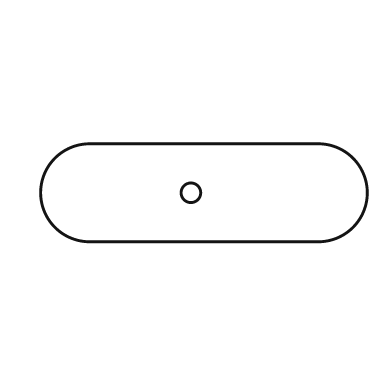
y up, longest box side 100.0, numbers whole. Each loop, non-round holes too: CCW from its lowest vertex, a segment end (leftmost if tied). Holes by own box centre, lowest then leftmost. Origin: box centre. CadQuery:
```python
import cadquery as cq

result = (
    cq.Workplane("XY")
    .moveTo(-35.0, -15.0)
    .lineTo(35.0, -15.0)
    .threePointArc((50.0, 0.0), (35.0, 15.0))
    .lineTo(-35.0, 15.0)
    .threePointArc((-50.0, 0.0), (-35.0, -15.0))
    .close()
    .moveTo(-4.0, 0.0)
    .circle(3.0)
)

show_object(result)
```